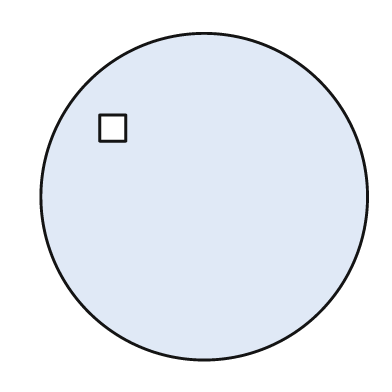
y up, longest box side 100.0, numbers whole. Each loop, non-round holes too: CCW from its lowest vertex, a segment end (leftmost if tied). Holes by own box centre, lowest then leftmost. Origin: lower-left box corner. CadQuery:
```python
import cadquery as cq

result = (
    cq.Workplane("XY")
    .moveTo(50.0, 50.0)
    .circle(50.0)
    .moveTo(18.0, 67.0)
    .lineTo(26.0, 67.0)
    .lineTo(26.0, 75.0)
    .lineTo(18.0, 75.0)
    .close()
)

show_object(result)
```